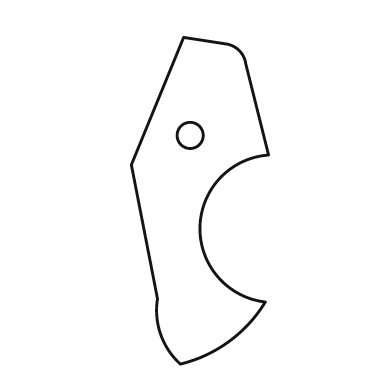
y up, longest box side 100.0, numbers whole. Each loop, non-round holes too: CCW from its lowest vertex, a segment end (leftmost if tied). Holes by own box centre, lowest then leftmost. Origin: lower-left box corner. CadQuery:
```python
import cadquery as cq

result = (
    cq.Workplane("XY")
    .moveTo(15.0, 0.0)
    .threePointArc((30.0, 7.0), (41.0, 19.0))
    .threePointArc((21.0, 42.0), (42.0, 64.0))
    .lineTo(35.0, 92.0)
    .threePointArc((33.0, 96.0), (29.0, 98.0))
    .lineTo(16.0, 100.0)
    .lineTo(0.0, 61.0)
    .lineTo(8.0, 20.0)
    .threePointArc((9.0, 9.0), (15.0, 0.0))
    .close()
    .moveTo(18.0, 70.0)
    .circle(4.0)
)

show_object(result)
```